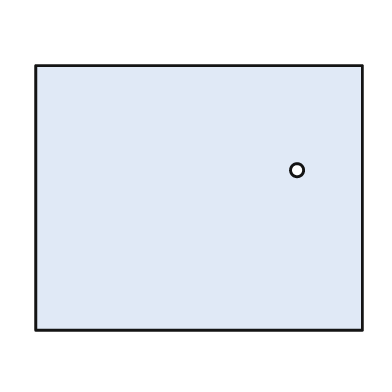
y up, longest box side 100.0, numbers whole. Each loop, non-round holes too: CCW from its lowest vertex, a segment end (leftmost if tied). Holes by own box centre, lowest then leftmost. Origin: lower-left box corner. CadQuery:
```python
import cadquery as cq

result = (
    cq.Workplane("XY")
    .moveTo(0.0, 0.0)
    .lineTo(100.0, 0.0)
    .lineTo(100.0, 81.0)
    .lineTo(0.0, 81.0)
    .close()
    .moveTo(80.0, 49.0)
    .circle(2.0)
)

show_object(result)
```